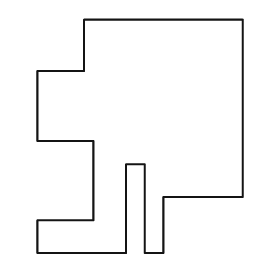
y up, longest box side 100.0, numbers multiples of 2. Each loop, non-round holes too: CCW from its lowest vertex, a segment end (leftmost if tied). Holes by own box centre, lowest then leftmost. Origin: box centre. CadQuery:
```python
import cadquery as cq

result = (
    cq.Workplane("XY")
    .moveTo(-44.0, -50.0)
    .lineTo(-6.0, -50.0)
    .lineTo(-6.0, -12.0)
    .lineTo(2.0, -12.0)
    .lineTo(2.0, -50.0)
    .lineTo(10.0, -50.0)
    .lineTo(10.0, -26.0)
    .lineTo(44.0, -26.0)
    .lineTo(44.0, 50.0)
    .lineTo(-24.0, 50.0)
    .lineTo(-24.0, 28.0)
    .lineTo(-44.0, 28.0)
    .lineTo(-44.0, -2.0)
    .lineTo(-20.0, -2.0)
    .lineTo(-20.0, -36.0)
    .lineTo(-44.0, -36.0)
    .close()
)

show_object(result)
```